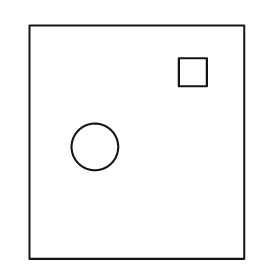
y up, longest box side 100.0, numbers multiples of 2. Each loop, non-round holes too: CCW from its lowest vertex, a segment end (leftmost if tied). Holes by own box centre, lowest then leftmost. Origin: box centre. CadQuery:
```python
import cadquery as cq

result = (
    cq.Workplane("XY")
    .moveTo(-46.0, -50.0)
    .lineTo(46.0, -50.0)
    .lineTo(46.0, 50.0)
    .lineTo(-46.0, 50.0)
    .close()
    .moveTo(-18.0, -2.0)
    .circle(10.0)
    .moveTo(18.0, 24.0)
    .lineTo(30.0, 24.0)
    .lineTo(30.0, 36.0)
    .lineTo(18.0, 36.0)
    .close()
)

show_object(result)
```